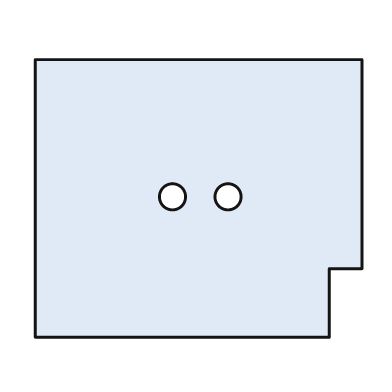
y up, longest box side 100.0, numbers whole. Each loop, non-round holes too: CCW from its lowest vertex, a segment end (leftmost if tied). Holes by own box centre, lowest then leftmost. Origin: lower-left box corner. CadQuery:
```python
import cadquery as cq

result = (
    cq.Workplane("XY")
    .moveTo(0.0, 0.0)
    .lineTo(90.0, 0.0)
    .lineTo(90.0, 21.0)
    .lineTo(100.0, 21.0)
    .lineTo(100.0, 85.0)
    .lineTo(0.0, 85.0)
    .close()
    .moveTo(42.0, 43.0)
    .circle(4.0)
    .moveTo(59.0, 43.0)
    .circle(4.0)
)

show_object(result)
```